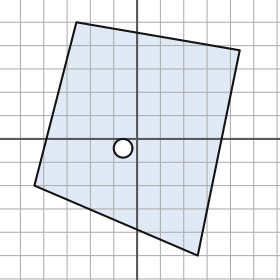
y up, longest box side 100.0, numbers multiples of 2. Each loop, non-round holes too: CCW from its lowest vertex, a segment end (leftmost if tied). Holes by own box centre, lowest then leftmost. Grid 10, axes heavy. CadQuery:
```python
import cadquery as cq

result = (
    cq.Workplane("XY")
    .moveTo(26.0, -50.0)
    .lineTo(44.0, 38.0)
    .lineTo(-26.0, 50.0)
    .lineTo(-44.0, -20.0)
    .close()
    .moveTo(-6.0, -4.0)
    .circle(4.0)
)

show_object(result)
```